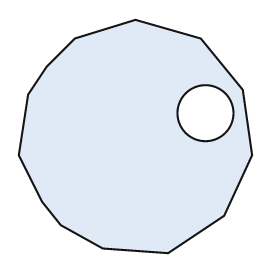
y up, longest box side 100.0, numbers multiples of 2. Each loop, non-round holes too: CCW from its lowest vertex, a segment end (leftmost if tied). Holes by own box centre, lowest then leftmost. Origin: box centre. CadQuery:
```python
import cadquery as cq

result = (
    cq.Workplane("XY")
    .moveTo(14.0, -50.0)
    .lineTo(38.0, -34.0)
    .lineTo(50.0, -8.0)
    .lineTo(46.0, 20.0)
    .lineTo(28.0, 42.0)
    .lineTo(0.0, 50.0)
    .lineTo(-26.0, 42.0)
    .lineTo(-38.0, 30.0)
    .lineTo(-46.0, 18.0)
    .lineTo(-50.0, -8.0)
    .lineTo(-40.0, -28.0)
    .lineTo(-32.0, -38.0)
    .lineTo(-14.0, -48.0)
    .close()
    .moveTo(30.0, 10.0)
    .circle(12.0)
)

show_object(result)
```